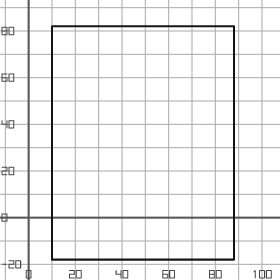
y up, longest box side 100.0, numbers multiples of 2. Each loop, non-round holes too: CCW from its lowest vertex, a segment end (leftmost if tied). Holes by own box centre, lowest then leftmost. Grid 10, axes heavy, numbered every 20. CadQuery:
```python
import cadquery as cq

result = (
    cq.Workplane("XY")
    .moveTo(10.0, -18.0)
    .lineTo(88.0, -18.0)
    .lineTo(88.0, 82.0)
    .lineTo(10.0, 82.0)
    .close()
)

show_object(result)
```